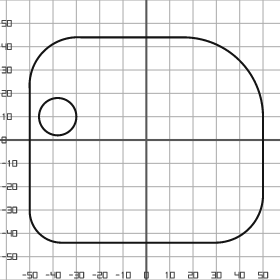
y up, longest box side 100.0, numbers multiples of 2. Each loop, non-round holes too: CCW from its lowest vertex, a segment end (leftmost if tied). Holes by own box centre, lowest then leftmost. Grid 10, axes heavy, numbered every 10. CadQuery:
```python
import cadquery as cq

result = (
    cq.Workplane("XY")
    .moveTo(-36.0, -44.0)
    .lineTo(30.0, -44.0)
    .threePointArc((44.0, -38.0), (50.0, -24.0))
    .lineTo(50.0, 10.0)
    .threePointArc((40.0, 34.0), (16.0, 44.0))
    .lineTo(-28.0, 44.0)
    .threePointArc((-44.0, 38.0), (-50.0, 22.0))
    .lineTo(-50.0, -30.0)
    .threePointArc((-46.0, -40.0), (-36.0, -44.0))
    .close()
    .moveTo(-38.0, 10.0)
    .circle(8.0)
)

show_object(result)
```